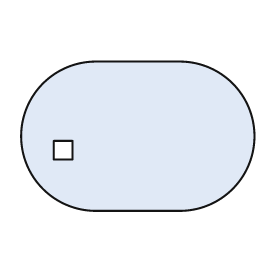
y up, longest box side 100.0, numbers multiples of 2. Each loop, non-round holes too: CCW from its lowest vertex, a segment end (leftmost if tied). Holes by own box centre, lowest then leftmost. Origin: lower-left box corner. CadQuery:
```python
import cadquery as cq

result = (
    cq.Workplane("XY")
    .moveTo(32.0, 0.0)
    .lineTo(68.0, 0.0)
    .threePointArc((100.0, 32.0), (68.0, 64.0))
    .lineTo(32.0, 64.0)
    .threePointArc((0.0, 32.0), (32.0, 0.0))
    .close()
    .moveTo(14.0, 22.0)
    .lineTo(22.0, 22.0)
    .lineTo(22.0, 30.0)
    .lineTo(14.0, 30.0)
    .close()
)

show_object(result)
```